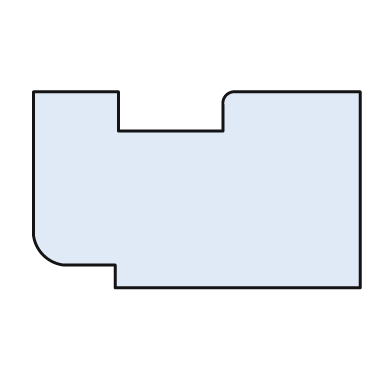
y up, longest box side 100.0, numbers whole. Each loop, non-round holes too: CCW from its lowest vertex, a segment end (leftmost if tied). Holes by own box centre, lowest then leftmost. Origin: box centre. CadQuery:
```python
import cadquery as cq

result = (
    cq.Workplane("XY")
    .moveTo(-25.0, -30.0)
    .lineTo(50.0, -30.0)
    .lineTo(50.0, 30.0)
    .lineTo(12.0, 30.0)
    .threePointArc((9.0, 29.0), (8.0, 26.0))
    .lineTo(8.0, 18.0)
    .lineTo(-24.0, 18.0)
    .lineTo(-24.0, 30.0)
    .lineTo(-50.0, 30.0)
    .lineTo(-50.0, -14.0)
    .threePointArc((-47.0, -20.0), (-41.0, -23.0))
    .lineTo(-25.0, -23.0)
    .close()
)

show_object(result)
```